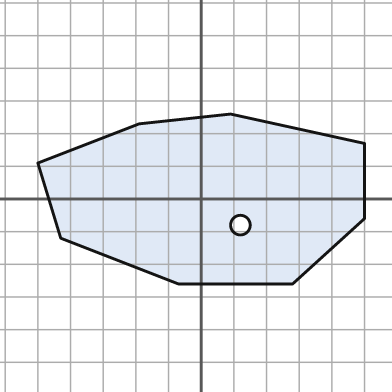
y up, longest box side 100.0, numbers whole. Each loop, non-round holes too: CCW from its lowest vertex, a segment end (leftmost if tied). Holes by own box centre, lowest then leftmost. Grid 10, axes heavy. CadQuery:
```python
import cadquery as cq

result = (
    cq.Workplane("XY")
    .moveTo(-7.0, -26.0)
    .lineTo(28.0, -26.0)
    .lineTo(50.0, -6.0)
    .lineTo(50.0, 17.0)
    .lineTo(9.0, 26.0)
    .lineTo(-19.0, 23.0)
    .lineTo(-50.0, 11.0)
    .lineTo(-43.0, -12.0)
    .close()
    .moveTo(12.0, -8.0)
    .circle(3.0)
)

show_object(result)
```